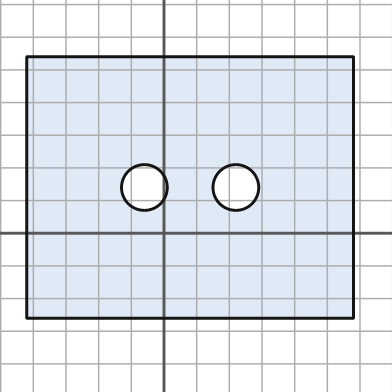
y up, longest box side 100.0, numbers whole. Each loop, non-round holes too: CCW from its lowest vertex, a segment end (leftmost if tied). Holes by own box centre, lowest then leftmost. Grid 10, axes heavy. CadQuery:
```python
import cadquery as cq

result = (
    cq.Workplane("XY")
    .moveTo(-42.0, -26.0)
    .lineTo(58.0, -26.0)
    .lineTo(58.0, 54.0)
    .lineTo(-42.0, 54.0)
    .close()
    .moveTo(-6.0, 14.0)
    .circle(7.0)
    .moveTo(22.0, 14.0)
    .circle(7.0)
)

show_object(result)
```